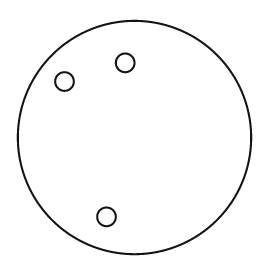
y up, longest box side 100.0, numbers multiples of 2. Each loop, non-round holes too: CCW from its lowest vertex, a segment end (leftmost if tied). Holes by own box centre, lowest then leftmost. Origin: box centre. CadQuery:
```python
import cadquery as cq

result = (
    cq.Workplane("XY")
    .moveTo(0.0, 0.0)
    .circle(50.0)
    .moveTo(-12.0, -34.0)
    .circle(4.0)
    .moveTo(-30.0, 24.0)
    .circle(4.0)
    .moveTo(-4.0, 32.0)
    .circle(4.0)
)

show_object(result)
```